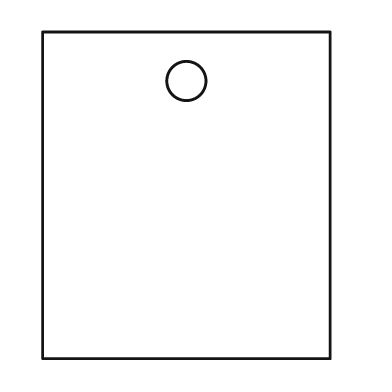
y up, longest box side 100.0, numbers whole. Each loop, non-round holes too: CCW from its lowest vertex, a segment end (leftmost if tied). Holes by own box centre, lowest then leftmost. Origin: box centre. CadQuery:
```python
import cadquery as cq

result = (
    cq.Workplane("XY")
    .moveTo(-44.0, -50.0)
    .lineTo(44.0, -50.0)
    .lineTo(44.0, 50.0)
    .lineTo(-44.0, 50.0)
    .close()
    .moveTo(0.0, 35.0)
    .circle(6.0)
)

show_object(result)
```